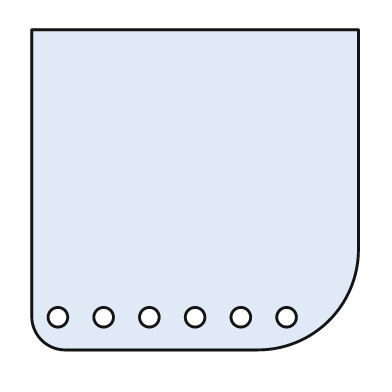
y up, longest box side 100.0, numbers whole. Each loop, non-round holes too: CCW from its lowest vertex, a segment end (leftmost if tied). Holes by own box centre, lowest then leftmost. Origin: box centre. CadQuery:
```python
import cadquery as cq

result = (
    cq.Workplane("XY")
    .moveTo(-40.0, -49.0)
    .lineTo(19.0, -49.0)
    .threePointArc((41.0, -40.0), (50.0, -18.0))
    .lineTo(50.0, 49.0)
    .lineTo(-50.0, 49.0)
    .lineTo(-50.0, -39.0)
    .threePointArc((-47.0, -46.0), (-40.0, -49.0))
    .close()
    .moveTo(-42.0, -39.0)
    .circle(3.0)
    .moveTo(-28.0, -39.0)
    .circle(3.0)
    .moveTo(-14.0, -39.0)
    .circle(3.0)
    .moveTo(0.0, -39.0)
    .circle(3.0)
    .moveTo(14.0, -39.0)
    .circle(3.0)
    .moveTo(28.0, -39.0)
    .circle(3.0)
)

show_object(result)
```